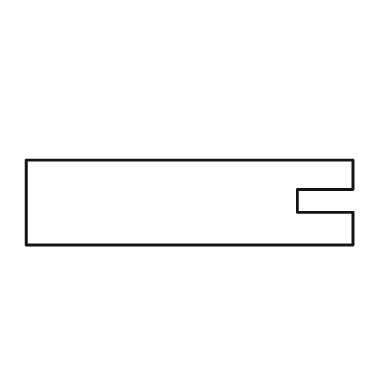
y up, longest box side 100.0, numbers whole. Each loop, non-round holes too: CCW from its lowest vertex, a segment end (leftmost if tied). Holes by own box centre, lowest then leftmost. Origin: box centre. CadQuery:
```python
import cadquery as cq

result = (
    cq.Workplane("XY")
    .moveTo(-50.0, -13.0)
    .lineTo(50.0, -13.0)
    .lineTo(50.0, -3.0)
    .lineTo(33.0, -3.0)
    .lineTo(33.0, 4.0)
    .lineTo(50.0, 4.0)
    .lineTo(50.0, 13.0)
    .lineTo(-50.0, 13.0)
    .close()
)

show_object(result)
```